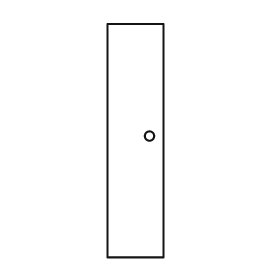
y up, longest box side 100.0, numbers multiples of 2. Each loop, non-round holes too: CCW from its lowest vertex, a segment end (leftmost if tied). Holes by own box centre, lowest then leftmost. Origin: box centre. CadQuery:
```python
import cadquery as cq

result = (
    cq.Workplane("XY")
    .moveTo(-12.0, -50.0)
    .lineTo(12.0, -50.0)
    .lineTo(12.0, 50.0)
    .lineTo(-12.0, 50.0)
    .close()
    .moveTo(6.0, 2.0)
    .circle(2.0)
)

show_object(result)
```